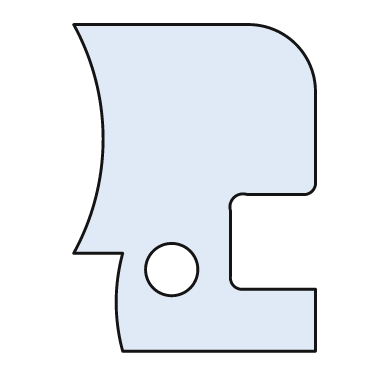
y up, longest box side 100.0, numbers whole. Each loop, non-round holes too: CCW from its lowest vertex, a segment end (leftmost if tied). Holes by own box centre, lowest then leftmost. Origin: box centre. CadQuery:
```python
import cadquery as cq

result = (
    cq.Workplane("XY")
    .moveTo(-22.0, -50.0)
    .lineTo(37.0, -50.0)
    .lineTo(37.0, -31.0)
    .lineTo(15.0, -31.0)
    .threePointArc((12.0, -30.0), (11.0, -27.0))
    .lineTo(11.0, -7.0)
    .threePointArc((12.0, -3.0), (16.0, -2.0))
    .lineTo(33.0, -2.0)
    .threePointArc((36.0, -1.0), (37.0, 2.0))
    .lineTo(37.0, 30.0)
    .threePointArc((31.0, 44.0), (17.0, 50.0))
    .lineTo(-37.0, 50.0)
    .threePointArc((-28.0, 15.0), (-37.0, -20.0))
    .lineTo(-22.0, -20.0)
    .threePointArc((-24.0, -35.0), (-22.0, -50.0))
    .close()
    .moveTo(-7.0, -25.0)
    .circle(8.0)
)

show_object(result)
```